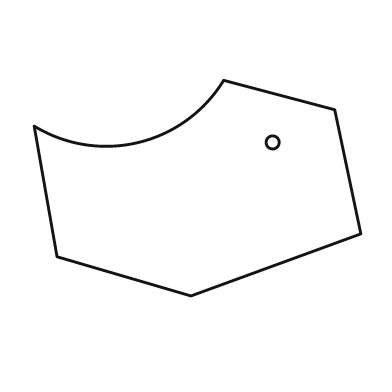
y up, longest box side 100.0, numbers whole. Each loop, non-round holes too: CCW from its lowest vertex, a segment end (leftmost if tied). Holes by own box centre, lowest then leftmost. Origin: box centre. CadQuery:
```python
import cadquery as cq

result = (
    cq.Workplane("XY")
    .moveTo(-2.0, -33.0)
    .lineTo(50.0, -14.0)
    .lineTo(42.0, 24.0)
    .lineTo(8.0, 33.0)
    .threePointArc((-18.0, 14.0), (-50.0, 19.0))
    .lineTo(-43.0, -21.0)
    .close()
    .moveTo(23.0, 14.0)
    .circle(2.0)
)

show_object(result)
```